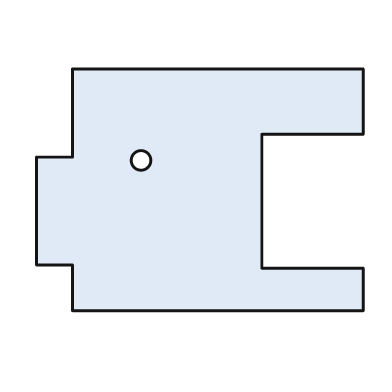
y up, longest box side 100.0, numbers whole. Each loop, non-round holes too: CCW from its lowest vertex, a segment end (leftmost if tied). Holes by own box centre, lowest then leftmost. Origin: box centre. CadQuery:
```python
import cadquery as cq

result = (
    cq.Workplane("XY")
    .moveTo(-39.0, -37.0)
    .lineTo(50.0, -37.0)
    .lineTo(50.0, -24.0)
    .lineTo(19.0, -24.0)
    .lineTo(19.0, 17.0)
    .lineTo(50.0, 17.0)
    .lineTo(50.0, 37.0)
    .lineTo(-39.0, 37.0)
    .lineTo(-39.0, 10.0)
    .lineTo(-50.0, 10.0)
    .lineTo(-50.0, -23.0)
    .lineTo(-39.0, -23.0)
    .close()
    .moveTo(-18.0, 9.0)
    .circle(3.0)
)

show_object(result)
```